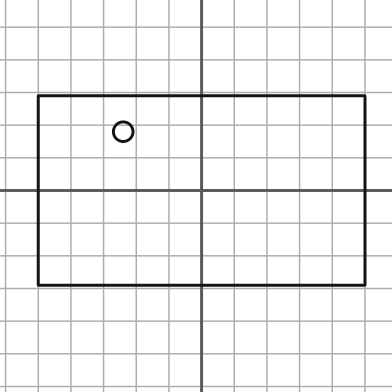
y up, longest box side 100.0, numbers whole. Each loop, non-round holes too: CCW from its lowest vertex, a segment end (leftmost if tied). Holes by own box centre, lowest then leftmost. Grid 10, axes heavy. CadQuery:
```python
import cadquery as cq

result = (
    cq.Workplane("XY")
    .moveTo(-50.0, -29.0)
    .lineTo(50.0, -29.0)
    .lineTo(50.0, 29.0)
    .lineTo(-50.0, 29.0)
    .close()
    .moveTo(-24.0, 18.0)
    .circle(3.0)
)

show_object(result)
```